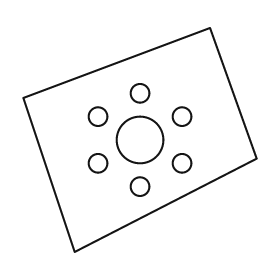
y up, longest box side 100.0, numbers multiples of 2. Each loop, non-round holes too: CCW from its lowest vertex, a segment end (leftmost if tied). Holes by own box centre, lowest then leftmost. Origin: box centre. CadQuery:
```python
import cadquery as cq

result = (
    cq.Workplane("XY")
    .moveTo(-28.0, -48.0)
    .lineTo(50.0, -8.0)
    .lineTo(30.0, 48.0)
    .lineTo(-50.0, 18.0)
    .close()
    .moveTo(0.0, -20.0)
    .circle(4.0)
    .moveTo(-18.0, -10.0)
    .circle(4.0)
    .moveTo(18.0, -10.0)
    .circle(4.0)
    .moveTo(0.0, 0.0)
    .circle(10.0)
    .moveTo(-18.0, 10.0)
    .circle(4.0)
    .moveTo(18.0, 10.0)
    .circle(4.0)
    .moveTo(0.0, 20.0)
    .circle(4.0)
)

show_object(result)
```